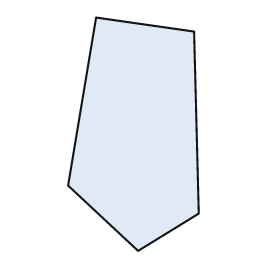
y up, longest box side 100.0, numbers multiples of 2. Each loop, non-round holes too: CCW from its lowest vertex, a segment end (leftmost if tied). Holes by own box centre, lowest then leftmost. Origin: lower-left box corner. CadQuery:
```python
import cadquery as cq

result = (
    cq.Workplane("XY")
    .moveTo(30.0, 0.0)
    .lineTo(56.0, 16.0)
    .lineTo(54.0, 94.0)
    .lineTo(12.0, 100.0)
    .lineTo(0.0, 28.0)
    .close()
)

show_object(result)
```